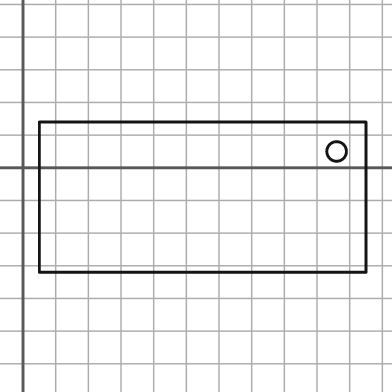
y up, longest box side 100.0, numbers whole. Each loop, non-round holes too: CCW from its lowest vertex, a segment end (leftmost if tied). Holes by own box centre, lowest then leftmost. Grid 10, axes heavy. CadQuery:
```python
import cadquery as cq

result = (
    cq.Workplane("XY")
    .moveTo(5.0, -32.0)
    .lineTo(105.0, -32.0)
    .lineTo(105.0, 14.0)
    .lineTo(5.0, 14.0)
    .close()
    .moveTo(96.0, 5.0)
    .circle(3.0)
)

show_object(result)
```